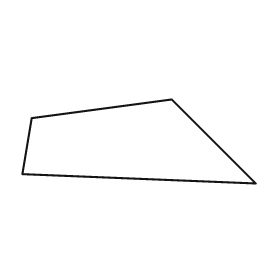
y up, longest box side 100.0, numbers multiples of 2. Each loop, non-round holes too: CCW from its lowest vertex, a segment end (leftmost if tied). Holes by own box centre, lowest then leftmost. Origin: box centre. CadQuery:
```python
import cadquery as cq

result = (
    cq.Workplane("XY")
    .moveTo(50.0, -18.0)
    .lineTo(14.0, 18.0)
    .lineTo(-46.0, 10.0)
    .lineTo(-50.0, -14.0)
    .close()
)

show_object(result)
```